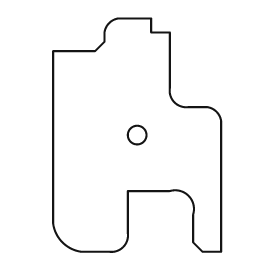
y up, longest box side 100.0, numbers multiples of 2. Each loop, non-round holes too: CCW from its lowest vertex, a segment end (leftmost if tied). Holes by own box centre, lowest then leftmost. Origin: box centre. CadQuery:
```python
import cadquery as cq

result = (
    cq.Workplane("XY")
    .moveTo(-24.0, -50.0)
    .lineTo(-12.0, -50.0)
    .threePointArc((-6.0, -48.0), (-4.0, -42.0))
    .lineTo(-4.0, -24.0)
    .lineTo(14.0, -24.0)
    .threePointArc((22.0, -26.0), (24.0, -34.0))
    .lineTo(24.0, -46.0)
    .lineTo(28.0, -50.0)
    .lineTo(36.0, -50.0)
    .lineTo(36.0, 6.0)
    .threePointArc((34.0, 10.0), (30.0, 12.0))
    .lineTo(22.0, 12.0)
    .threePointArc((16.0, 14.0), (14.0, 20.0))
    .lineTo(14.0, 44.0)
    .lineTo(6.0, 44.0)
    .lineTo(6.0, 50.0)
    .lineTo(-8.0, 50.0)
    .threePointArc((-12.0, 48.0), (-14.0, 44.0))
    .lineTo(-14.0, 40.0)
    .lineTo(-18.0, 36.0)
    .lineTo(-36.0, 36.0)
    .lineTo(-36.0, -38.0)
    .threePointArc((-32.0, -46.0), (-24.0, -50.0))
    .close()
    .moveTo(0.0, 0.0)
    .circle(4.0)
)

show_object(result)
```